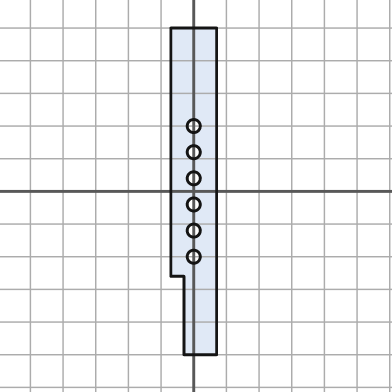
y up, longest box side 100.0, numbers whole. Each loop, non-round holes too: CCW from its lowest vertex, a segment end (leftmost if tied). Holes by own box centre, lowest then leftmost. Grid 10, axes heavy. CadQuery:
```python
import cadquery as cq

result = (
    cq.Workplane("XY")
    .moveTo(-3.0, -50.0)
    .lineTo(7.0, -50.0)
    .lineTo(7.0, 50.0)
    .lineTo(-7.0, 50.0)
    .lineTo(-7.0, -26.0)
    .lineTo(-3.0, -26.0)
    .close()
    .moveTo(0.0, -20.0)
    .circle(2.0)
    .moveTo(0.0, -12.0)
    .circle(2.0)
    .moveTo(0.0, -4.0)
    .circle(2.0)
    .moveTo(0.0, 4.0)
    .circle(2.0)
    .moveTo(0.0, 12.0)
    .circle(2.0)
    .moveTo(0.0, 20.0)
    .circle(2.0)
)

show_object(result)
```